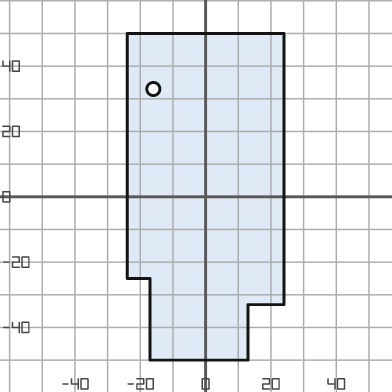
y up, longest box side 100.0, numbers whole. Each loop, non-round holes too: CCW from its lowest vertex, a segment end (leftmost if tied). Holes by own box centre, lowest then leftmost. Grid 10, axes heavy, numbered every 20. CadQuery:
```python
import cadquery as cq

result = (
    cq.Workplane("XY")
    .moveTo(-17.0, -50.0)
    .lineTo(13.0, -50.0)
    .lineTo(13.0, -33.0)
    .lineTo(24.0, -33.0)
    .lineTo(24.0, 50.0)
    .lineTo(-24.0, 50.0)
    .lineTo(-24.0, -25.0)
    .lineTo(-17.0, -25.0)
    .close()
    .moveTo(-16.0, 33.0)
    .circle(2.0)
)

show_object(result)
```